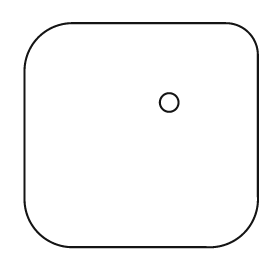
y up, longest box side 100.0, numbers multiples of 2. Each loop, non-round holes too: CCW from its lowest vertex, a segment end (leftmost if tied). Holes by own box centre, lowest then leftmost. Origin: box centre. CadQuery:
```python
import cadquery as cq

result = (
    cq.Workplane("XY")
    .moveTo(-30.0, -48.0)
    .lineTo(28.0, -48.0)
    .threePointArc((44.0, -42.0), (50.0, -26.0))
    .lineTo(50.0, 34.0)
    .threePointArc((46.0, 44.0), (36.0, 48.0))
    .lineTo(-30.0, 48.0)
    .threePointArc((-44.0, 42.0), (-50.0, 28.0))
    .lineTo(-50.0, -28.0)
    .threePointArc((-44.0, -42.0), (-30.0, -48.0))
    .close()
    .moveTo(12.0, 14.0)
    .circle(4.0)
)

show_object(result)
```